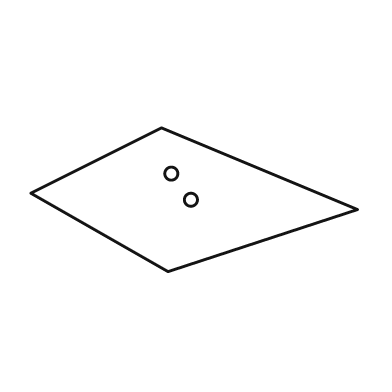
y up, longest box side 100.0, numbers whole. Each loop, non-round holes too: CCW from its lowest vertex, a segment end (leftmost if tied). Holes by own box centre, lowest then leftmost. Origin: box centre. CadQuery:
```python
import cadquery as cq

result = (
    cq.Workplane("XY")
    .moveTo(-8.0, -22.0)
    .lineTo(50.0, -3.0)
    .lineTo(-10.0, 22.0)
    .lineTo(-50.0, 2.0)
    .close()
    .moveTo(-1.0, 0.0)
    .circle(2.0)
    .moveTo(-7.0, 8.0)
    .circle(2.0)
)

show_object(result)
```